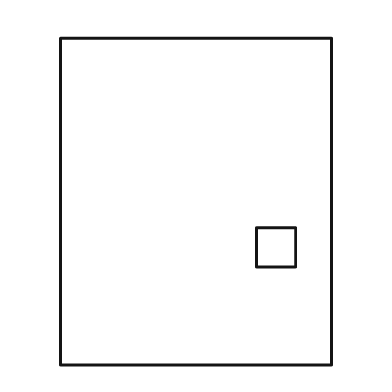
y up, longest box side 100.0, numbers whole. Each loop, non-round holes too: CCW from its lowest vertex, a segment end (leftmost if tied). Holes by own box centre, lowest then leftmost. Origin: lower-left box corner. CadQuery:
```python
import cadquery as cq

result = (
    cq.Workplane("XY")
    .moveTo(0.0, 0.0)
    .lineTo(83.0, 0.0)
    .lineTo(83.0, 100.0)
    .lineTo(0.0, 100.0)
    .close()
    .moveTo(60.0, 30.0)
    .lineTo(72.0, 30.0)
    .lineTo(72.0, 42.0)
    .lineTo(60.0, 42.0)
    .close()
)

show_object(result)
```